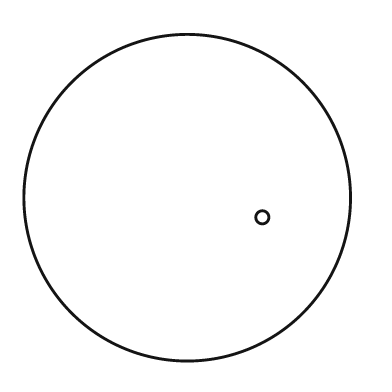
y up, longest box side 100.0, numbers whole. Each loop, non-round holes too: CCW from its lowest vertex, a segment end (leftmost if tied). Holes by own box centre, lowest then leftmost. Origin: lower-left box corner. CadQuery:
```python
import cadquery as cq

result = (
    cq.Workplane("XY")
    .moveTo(50.0, 50.0)
    .circle(50.0)
    .moveTo(73.0, 44.0)
    .circle(2.0)
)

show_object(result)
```